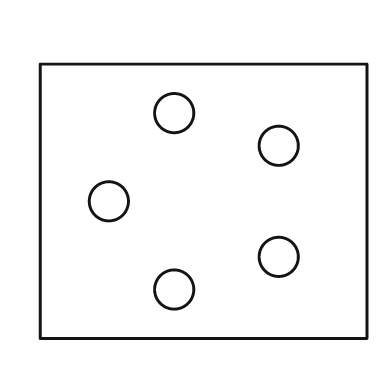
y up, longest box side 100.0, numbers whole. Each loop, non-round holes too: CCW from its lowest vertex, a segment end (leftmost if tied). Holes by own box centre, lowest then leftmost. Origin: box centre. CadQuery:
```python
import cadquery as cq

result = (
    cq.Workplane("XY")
    .moveTo(-50.0, -42.0)
    .lineTo(50.0, -42.0)
    .lineTo(50.0, 42.0)
    .lineTo(-50.0, 42.0)
    .close()
    .moveTo(-9.0, -27.0)
    .circle(6.0)
    .moveTo(23.0, -17.0)
    .circle(6.0)
    .moveTo(-29.0, 0.0)
    .circle(6.0)
    .moveTo(23.0, 17.0)
    .circle(6.0)
    .moveTo(-9.0, 27.0)
    .circle(6.0)
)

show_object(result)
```